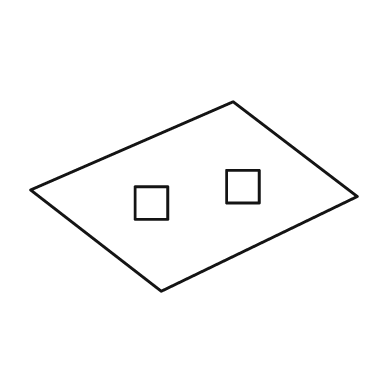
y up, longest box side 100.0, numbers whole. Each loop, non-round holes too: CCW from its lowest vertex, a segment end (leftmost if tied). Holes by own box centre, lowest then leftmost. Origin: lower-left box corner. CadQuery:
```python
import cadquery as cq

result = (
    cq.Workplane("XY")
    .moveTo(40.0, 0.0)
    .lineTo(100.0, 29.0)
    .lineTo(62.0, 58.0)
    .lineTo(0.0, 31.0)
    .close()
    .moveTo(32.0, 22.0)
    .lineTo(42.0, 22.0)
    .lineTo(42.0, 32.0)
    .lineTo(32.0, 32.0)
    .close()
    .moveTo(60.0, 27.0)
    .lineTo(70.0, 27.0)
    .lineTo(70.0, 37.0)
    .lineTo(60.0, 37.0)
    .close()
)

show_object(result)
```